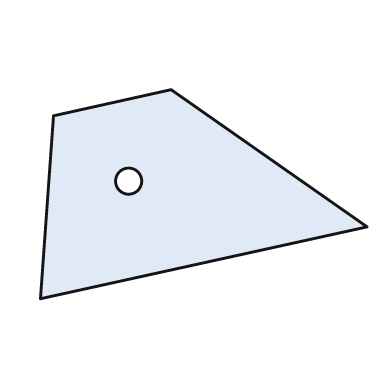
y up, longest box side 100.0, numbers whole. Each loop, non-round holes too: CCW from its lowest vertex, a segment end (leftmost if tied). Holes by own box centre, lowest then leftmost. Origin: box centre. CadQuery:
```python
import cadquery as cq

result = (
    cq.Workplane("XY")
    .moveTo(-50.0, -32.0)
    .lineTo(50.0, -10.0)
    .lineTo(-10.0, 32.0)
    .lineTo(-46.0, 24.0)
    .close()
    .moveTo(-23.0, 4.0)
    .circle(4.0)
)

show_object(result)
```